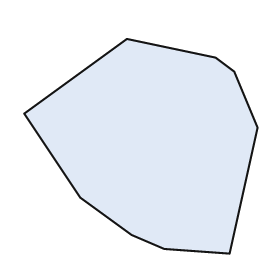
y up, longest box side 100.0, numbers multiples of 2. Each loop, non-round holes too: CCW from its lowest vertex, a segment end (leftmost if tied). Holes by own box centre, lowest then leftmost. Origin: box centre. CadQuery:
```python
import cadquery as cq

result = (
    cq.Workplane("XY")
    .moveTo(38.0, -46.0)
    .lineTo(50.0, 8.0)
    .lineTo(40.0, 32.0)
    .lineTo(32.0, 38.0)
    .lineTo(-6.0, 46.0)
    .lineTo(-50.0, 14.0)
    .lineTo(-26.0, -22.0)
    .lineTo(-4.0, -38.0)
    .lineTo(10.0, -44.0)
    .close()
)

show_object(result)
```